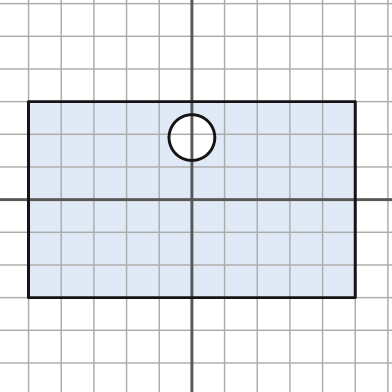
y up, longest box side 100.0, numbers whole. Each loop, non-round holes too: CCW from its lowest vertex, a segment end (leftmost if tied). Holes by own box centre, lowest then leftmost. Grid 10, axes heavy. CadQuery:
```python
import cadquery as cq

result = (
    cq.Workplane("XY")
    .moveTo(-50.0, -30.0)
    .lineTo(50.0, -30.0)
    .lineTo(50.0, 30.0)
    .lineTo(-50.0, 30.0)
    .close()
    .moveTo(0.0, 19.0)
    .circle(7.0)
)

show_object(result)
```